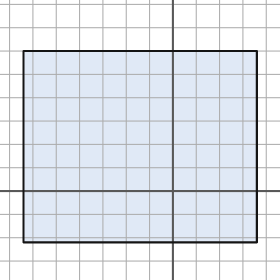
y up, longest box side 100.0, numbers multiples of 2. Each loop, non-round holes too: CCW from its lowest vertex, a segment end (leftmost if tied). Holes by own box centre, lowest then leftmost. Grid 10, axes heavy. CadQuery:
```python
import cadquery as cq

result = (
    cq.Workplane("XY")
    .moveTo(-64.0, -22.0)
    .lineTo(36.0, -22.0)
    .lineTo(36.0, 60.0)
    .lineTo(-64.0, 60.0)
    .close()
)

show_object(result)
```